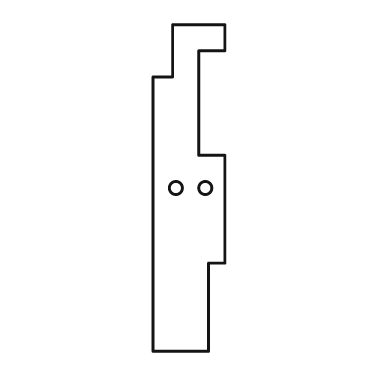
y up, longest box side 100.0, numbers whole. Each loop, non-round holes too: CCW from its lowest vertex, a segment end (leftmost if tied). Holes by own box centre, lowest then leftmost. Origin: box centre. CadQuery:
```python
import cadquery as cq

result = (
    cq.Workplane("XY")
    .moveTo(-11.0, -50.0)
    .lineTo(6.0, -50.0)
    .lineTo(6.0, -23.0)
    .lineTo(11.0, -23.0)
    .lineTo(11.0, 10.0)
    .lineTo(3.0, 10.0)
    .lineTo(3.0, 42.0)
    .lineTo(11.0, 42.0)
    .lineTo(11.0, 50.0)
    .lineTo(-5.0, 50.0)
    .lineTo(-5.0, 34.0)
    .lineTo(-11.0, 34.0)
    .close()
    .moveTo(-4.0, 0.0)
    .circle(2.0)
    .moveTo(5.0, 0.0)
    .circle(2.0)
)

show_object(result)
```